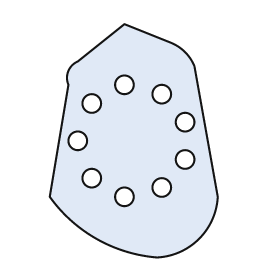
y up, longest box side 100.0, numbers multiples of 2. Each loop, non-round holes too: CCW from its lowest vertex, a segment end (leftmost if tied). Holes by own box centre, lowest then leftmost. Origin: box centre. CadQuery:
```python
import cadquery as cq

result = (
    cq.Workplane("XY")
    .moveTo(10.0, -50.0)
    .threePointArc((28.0, -42.0), (36.0, -24.0))
    .lineTo(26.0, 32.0)
    .threePointArc((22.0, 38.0), (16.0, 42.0))
    .lineTo(-4.0, 50.0)
    .lineTo(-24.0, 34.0)
    .threePointArc((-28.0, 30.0), (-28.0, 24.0))
    .lineTo(-36.0, -24.0)
    .threePointArc((-16.0, -42.0), (10.0, -50.0))
    .close()
    .moveTo(-4.0, -24.0)
    .circle(4.0)
    .moveTo(12.0, -20.0)
    .circle(4.0)
    .moveTo(-18.0, -16.0)
    .circle(4.0)
    .moveTo(22.0, -8.0)
    .circle(4.0)
    .moveTo(-24.0, 0.0)
    .circle(4.0)
    .moveTo(22.0, 8.0)
    .circle(4.0)
    .moveTo(-18.0, 16.0)
    .circle(4.0)
    .moveTo(12.0, 20.0)
    .circle(4.0)
    .moveTo(-4.0, 24.0)
    .circle(4.0)
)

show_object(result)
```